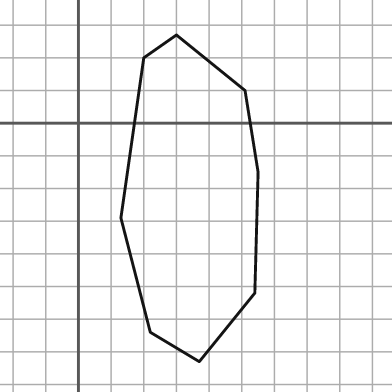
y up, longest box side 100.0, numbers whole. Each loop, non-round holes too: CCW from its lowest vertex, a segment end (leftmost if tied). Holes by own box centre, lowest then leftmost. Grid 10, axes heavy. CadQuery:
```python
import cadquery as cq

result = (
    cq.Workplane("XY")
    .moveTo(37.0, -73.0)
    .lineTo(54.0, -52.0)
    .lineTo(55.0, -15.0)
    .lineTo(51.0, 10.0)
    .lineTo(30.0, 27.0)
    .lineTo(20.0, 20.0)
    .lineTo(13.0, -29.0)
    .lineTo(22.0, -64.0)
    .close()
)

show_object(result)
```